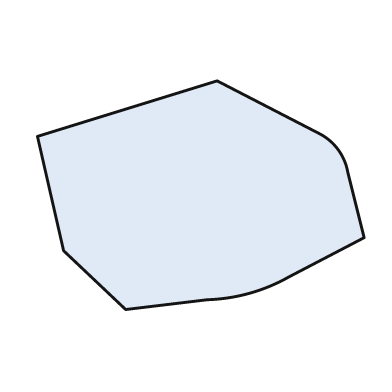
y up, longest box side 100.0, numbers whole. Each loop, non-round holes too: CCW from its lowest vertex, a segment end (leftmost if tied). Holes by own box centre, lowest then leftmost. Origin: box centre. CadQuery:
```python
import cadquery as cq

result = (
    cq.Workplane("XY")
    .moveTo(-23.0, -35.0)
    .lineTo(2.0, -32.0)
    .threePointArc((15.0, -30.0), (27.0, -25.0))
    .lineTo(50.0, -13.0)
    .lineTo(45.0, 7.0)
    .threePointArc((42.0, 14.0), (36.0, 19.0))
    .lineTo(5.0, 35.0)
    .lineTo(-50.0, 18.0)
    .lineTo(-42.0, -17.0)
    .close()
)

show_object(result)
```